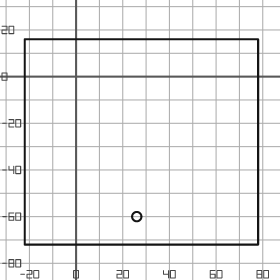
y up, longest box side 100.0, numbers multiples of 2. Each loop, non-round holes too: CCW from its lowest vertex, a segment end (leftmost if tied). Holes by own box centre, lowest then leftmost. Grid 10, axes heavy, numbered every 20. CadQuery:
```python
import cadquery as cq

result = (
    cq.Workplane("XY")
    .moveTo(-22.0, -72.0)
    .lineTo(78.0, -72.0)
    .lineTo(78.0, 16.0)
    .lineTo(-22.0, 16.0)
    .close()
    .moveTo(26.0, -60.0)
    .circle(2.0)
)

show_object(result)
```